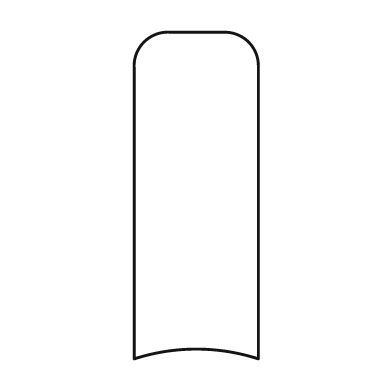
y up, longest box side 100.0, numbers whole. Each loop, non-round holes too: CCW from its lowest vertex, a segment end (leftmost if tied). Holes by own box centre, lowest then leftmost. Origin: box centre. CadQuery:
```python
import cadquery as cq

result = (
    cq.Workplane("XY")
    .moveTo(-19.0, -50.0)
    .threePointArc((0.0, -47.0), (19.0, -50.0))
    .lineTo(19.0, 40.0)
    .threePointArc((16.0, 47.0), (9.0, 50.0))
    .lineTo(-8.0, 50.0)
    .threePointArc((-16.0, 47.0), (-19.0, 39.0))
    .close()
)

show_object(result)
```